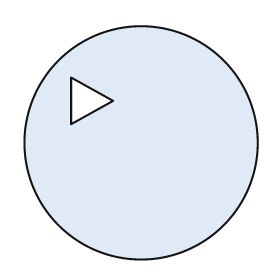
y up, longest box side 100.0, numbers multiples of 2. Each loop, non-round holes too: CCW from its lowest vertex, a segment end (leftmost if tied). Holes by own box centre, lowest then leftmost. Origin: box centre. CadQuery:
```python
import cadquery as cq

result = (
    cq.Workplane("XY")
    .moveTo(0.0, 0.0)
    .circle(50.0)
    .moveTo(-30.0, 8.0)
    .lineTo(-12.0, 18.0)
    .lineTo(-30.0, 28.0)
    .close()
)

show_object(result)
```